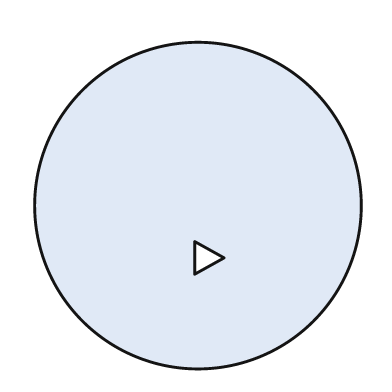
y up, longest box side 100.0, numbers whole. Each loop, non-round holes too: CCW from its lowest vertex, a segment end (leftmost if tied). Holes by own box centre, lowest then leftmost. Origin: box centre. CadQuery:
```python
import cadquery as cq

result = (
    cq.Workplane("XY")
    .moveTo(0.0, 0.0)
    .circle(50.0)
    .moveTo(-1.0, -21.0)
    .lineTo(8.0, -16.0)
    .lineTo(-1.0, -11.0)
    .close()
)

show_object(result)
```